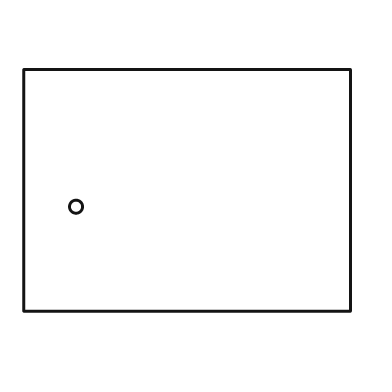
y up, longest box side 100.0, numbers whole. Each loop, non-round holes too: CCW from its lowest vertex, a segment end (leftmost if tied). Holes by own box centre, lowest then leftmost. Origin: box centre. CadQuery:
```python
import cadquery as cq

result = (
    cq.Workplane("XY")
    .moveTo(-50.0, -37.0)
    .lineTo(50.0, -37.0)
    .lineTo(50.0, 37.0)
    .lineTo(-50.0, 37.0)
    .close()
    .moveTo(-34.0, -5.0)
    .circle(2.0)
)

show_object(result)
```